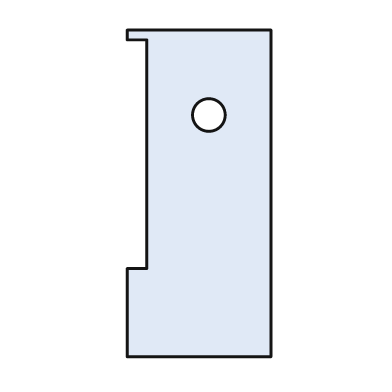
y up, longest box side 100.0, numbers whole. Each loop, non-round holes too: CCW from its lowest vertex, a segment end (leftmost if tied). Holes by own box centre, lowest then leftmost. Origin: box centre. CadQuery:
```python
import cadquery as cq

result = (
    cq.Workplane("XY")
    .moveTo(-22.0, -50.0)
    .lineTo(22.0, -50.0)
    .lineTo(22.0, 50.0)
    .lineTo(-22.0, 50.0)
    .lineTo(-22.0, 47.0)
    .lineTo(-16.0, 47.0)
    .lineTo(-16.0, -23.0)
    .lineTo(-22.0, -23.0)
    .close()
    .moveTo(3.0, 24.0)
    .circle(5.0)
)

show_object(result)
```